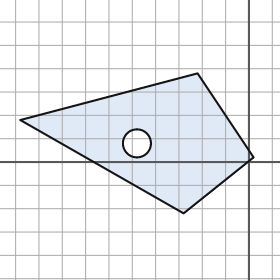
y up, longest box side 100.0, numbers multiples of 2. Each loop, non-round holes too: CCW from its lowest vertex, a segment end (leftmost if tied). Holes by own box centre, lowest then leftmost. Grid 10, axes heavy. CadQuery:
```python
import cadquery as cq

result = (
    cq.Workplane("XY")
    .moveTo(-28.0, -22.0)
    .lineTo(2.0, 2.0)
    .lineTo(-22.0, 38.0)
    .lineTo(-98.0, 18.0)
    .close()
    .moveTo(-48.0, 8.0)
    .circle(6.0)
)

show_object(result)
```